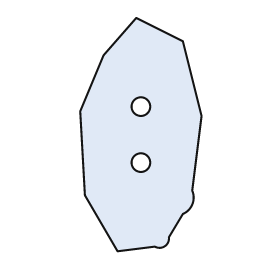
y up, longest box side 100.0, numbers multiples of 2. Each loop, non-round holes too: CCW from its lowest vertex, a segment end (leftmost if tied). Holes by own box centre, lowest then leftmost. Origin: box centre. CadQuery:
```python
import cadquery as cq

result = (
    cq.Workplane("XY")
    .moveTo(-10.0, -50.0)
    .lineTo(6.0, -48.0)
    .threePointArc((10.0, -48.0), (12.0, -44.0))
    .lineTo(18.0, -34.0)
    .threePointArc((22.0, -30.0), (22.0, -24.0))
    .lineTo(26.0, 8.0)
    .lineTo(18.0, 40.0)
    .lineTo(-2.0, 50.0)
    .lineTo(-16.0, 34.0)
    .lineTo(-26.0, 10.0)
    .lineTo(-24.0, -26.0)
    .close()
    .moveTo(0.0, -12.0)
    .circle(4.0)
    .moveTo(0.0, 12.0)
    .circle(4.0)
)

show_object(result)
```